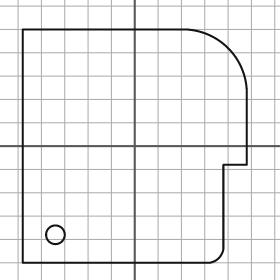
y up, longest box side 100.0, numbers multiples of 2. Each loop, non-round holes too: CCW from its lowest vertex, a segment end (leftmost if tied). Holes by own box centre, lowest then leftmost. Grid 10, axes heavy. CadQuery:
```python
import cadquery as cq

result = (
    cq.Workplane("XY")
    .moveTo(-48.0, -50.0)
    .lineTo(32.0, -50.0)
    .threePointArc((36.0, -48.0), (38.0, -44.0))
    .lineTo(38.0, -8.0)
    .lineTo(48.0, -8.0)
    .lineTo(48.0, 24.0)
    .threePointArc((40.0, 42.0), (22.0, 50.0))
    .lineTo(-48.0, 50.0)
    .close()
    .moveTo(-34.0, -38.0)
    .circle(4.0)
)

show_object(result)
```